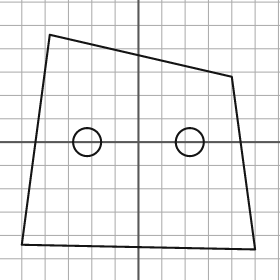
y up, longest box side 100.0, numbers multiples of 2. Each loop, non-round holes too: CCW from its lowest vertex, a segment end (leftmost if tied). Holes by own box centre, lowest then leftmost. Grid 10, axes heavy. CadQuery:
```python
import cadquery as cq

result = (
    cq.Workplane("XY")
    .moveTo(50.0, -46.0)
    .lineTo(40.0, 28.0)
    .lineTo(-38.0, 46.0)
    .lineTo(-50.0, -44.0)
    .close()
    .moveTo(-22.0, 0.0)
    .circle(6.0)
    .moveTo(22.0, 0.0)
    .circle(6.0)
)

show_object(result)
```